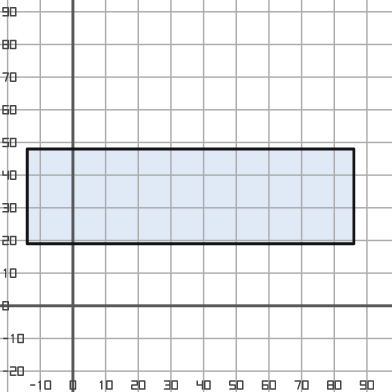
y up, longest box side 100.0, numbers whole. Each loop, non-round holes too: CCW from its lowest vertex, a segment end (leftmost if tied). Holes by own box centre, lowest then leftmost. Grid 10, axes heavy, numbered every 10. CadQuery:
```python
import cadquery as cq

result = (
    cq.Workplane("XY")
    .moveTo(-14.0, 19.0)
    .lineTo(86.0, 19.0)
    .lineTo(86.0, 48.0)
    .lineTo(-14.0, 48.0)
    .close()
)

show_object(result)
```